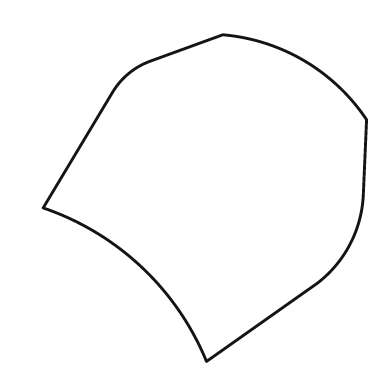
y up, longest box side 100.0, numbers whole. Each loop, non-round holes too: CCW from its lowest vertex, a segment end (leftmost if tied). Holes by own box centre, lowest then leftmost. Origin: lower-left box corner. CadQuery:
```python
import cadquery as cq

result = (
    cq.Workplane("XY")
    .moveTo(50.0, 0.0)
    .lineTo(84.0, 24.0)
    .threePointArc((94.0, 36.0), (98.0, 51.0))
    .lineTo(99.0, 74.0)
    .threePointArc((80.0, 92.0), (55.0, 100.0))
    .lineTo(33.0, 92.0)
    .threePointArc((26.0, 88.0), (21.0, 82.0))
    .lineTo(0.0, 47.0)
    .threePointArc((30.0, 29.0), (50.0, 0.0))
    .close()
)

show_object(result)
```